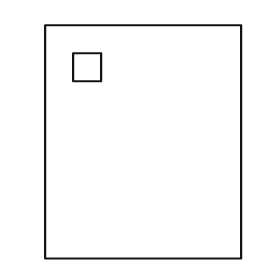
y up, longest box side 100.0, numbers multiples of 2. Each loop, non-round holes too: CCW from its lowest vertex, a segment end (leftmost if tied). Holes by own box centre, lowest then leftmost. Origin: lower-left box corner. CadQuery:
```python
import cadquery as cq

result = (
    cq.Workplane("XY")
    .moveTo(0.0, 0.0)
    .lineTo(84.0, 0.0)
    .lineTo(84.0, 100.0)
    .lineTo(0.0, 100.0)
    .close()
    .moveTo(12.0, 76.0)
    .lineTo(24.0, 76.0)
    .lineTo(24.0, 88.0)
    .lineTo(12.0, 88.0)
    .close()
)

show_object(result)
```